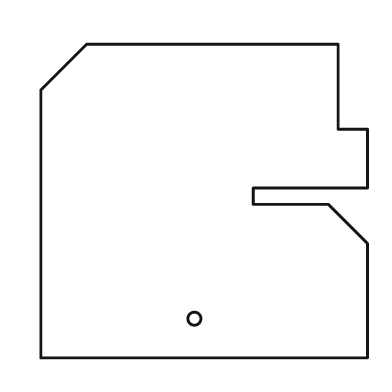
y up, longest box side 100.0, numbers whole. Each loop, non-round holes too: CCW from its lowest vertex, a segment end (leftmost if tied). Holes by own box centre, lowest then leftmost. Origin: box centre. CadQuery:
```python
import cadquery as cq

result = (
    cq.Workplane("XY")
    .moveTo(-50.0, -48.0)
    .lineTo(50.0, -48.0)
    .lineTo(50.0, -13.0)
    .lineTo(38.0, -1.0)
    .lineTo(15.0, -1.0)
    .lineTo(15.0, 4.0)
    .lineTo(50.0, 4.0)
    .lineTo(50.0, 22.0)
    .lineTo(41.0, 22.0)
    .lineTo(41.0, 48.0)
    .lineTo(-36.0, 48.0)
    .lineTo(-50.0, 34.0)
    .close()
    .moveTo(-3.0, -36.0)
    .circle(2.0)
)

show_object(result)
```